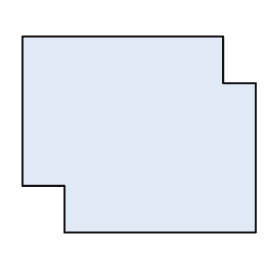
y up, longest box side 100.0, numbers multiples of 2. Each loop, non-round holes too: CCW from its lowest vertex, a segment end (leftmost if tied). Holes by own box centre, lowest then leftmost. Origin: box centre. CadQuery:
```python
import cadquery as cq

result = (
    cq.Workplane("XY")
    .moveTo(-32.0, -42.0)
    .lineTo(50.0, -42.0)
    .lineTo(50.0, 22.0)
    .lineTo(36.0, 22.0)
    .lineTo(36.0, 42.0)
    .lineTo(-50.0, 42.0)
    .lineTo(-50.0, -22.0)
    .lineTo(-32.0, -22.0)
    .close()
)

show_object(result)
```